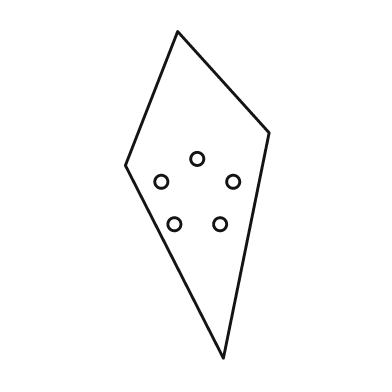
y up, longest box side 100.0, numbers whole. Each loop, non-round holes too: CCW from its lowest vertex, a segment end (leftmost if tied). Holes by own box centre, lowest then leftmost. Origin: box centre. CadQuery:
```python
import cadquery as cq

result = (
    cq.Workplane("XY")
    .moveTo(8.0, -50.0)
    .lineTo(22.0, 19.0)
    .lineTo(-6.0, 50.0)
    .lineTo(-22.0, 9.0)
    .close()
    .moveTo(-7.0, -9.0)
    .circle(2.0)
    .moveTo(7.0, -9.0)
    .circle(2.0)
    .moveTo(-11.0, 4.0)
    .circle(2.0)
    .moveTo(11.0, 4.0)
    .circle(2.0)
    .moveTo(0.0, 11.0)
    .circle(2.0)
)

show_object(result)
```